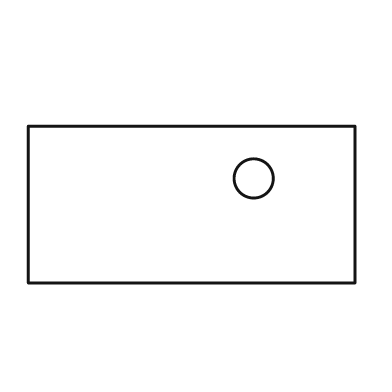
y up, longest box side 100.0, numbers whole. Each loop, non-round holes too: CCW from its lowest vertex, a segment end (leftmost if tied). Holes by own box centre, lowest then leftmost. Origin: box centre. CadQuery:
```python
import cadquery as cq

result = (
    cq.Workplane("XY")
    .moveTo(-50.0, -24.0)
    .lineTo(50.0, -24.0)
    .lineTo(50.0, 24.0)
    .lineTo(-50.0, 24.0)
    .close()
    .moveTo(19.0, 8.0)
    .circle(6.0)
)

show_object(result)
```